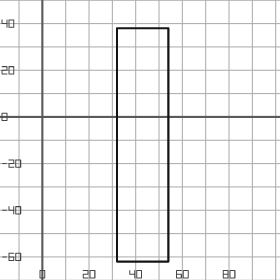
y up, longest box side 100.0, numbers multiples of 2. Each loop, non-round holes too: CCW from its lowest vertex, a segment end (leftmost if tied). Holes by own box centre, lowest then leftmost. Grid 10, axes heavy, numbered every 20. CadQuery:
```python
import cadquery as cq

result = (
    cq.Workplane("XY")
    .moveTo(32.0, -62.0)
    .lineTo(54.0, -62.0)
    .lineTo(54.0, 38.0)
    .lineTo(32.0, 38.0)
    .close()
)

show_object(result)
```